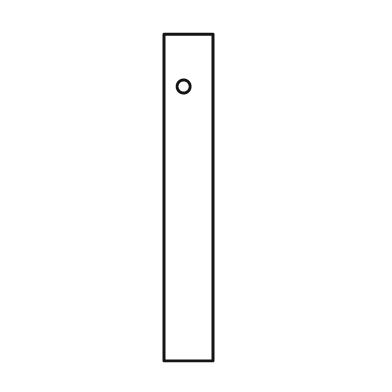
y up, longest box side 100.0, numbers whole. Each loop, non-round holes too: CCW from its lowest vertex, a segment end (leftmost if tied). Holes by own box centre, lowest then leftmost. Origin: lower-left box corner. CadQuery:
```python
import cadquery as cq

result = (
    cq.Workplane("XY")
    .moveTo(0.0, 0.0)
    .lineTo(15.0, 0.0)
    .lineTo(15.0, 100.0)
    .lineTo(0.0, 100.0)
    .close()
    .moveTo(6.0, 84.0)
    .circle(2.0)
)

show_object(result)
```